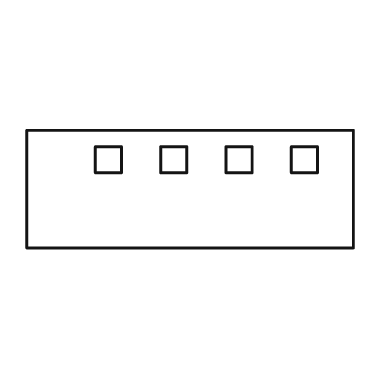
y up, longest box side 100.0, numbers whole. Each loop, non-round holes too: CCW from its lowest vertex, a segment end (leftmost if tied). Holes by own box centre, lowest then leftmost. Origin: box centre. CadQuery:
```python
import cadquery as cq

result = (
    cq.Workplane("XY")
    .moveTo(-50.0, -18.0)
    .lineTo(50.0, -18.0)
    .lineTo(50.0, 18.0)
    .lineTo(-50.0, 18.0)
    .close()
    .moveTo(-29.0, 5.0)
    .lineTo(-21.0, 5.0)
    .lineTo(-21.0, 13.0)
    .lineTo(-29.0, 13.0)
    .close()
    .moveTo(-9.0, 5.0)
    .lineTo(-1.0, 5.0)
    .lineTo(-1.0, 13.0)
    .lineTo(-9.0, 13.0)
    .close()
    .moveTo(11.0, 5.0)
    .lineTo(19.0, 5.0)
    .lineTo(19.0, 13.0)
    .lineTo(11.0, 13.0)
    .close()
    .moveTo(31.0, 5.0)
    .lineTo(39.0, 5.0)
    .lineTo(39.0, 13.0)
    .lineTo(31.0, 13.0)
    .close()
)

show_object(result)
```